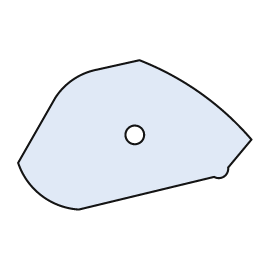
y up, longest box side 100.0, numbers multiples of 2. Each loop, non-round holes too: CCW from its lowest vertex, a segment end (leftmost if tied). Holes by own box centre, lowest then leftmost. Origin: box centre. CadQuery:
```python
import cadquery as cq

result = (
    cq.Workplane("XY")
    .moveTo(-24.0, -32.0)
    .lineTo(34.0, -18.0)
    .threePointArc((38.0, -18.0), (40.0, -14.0))
    .lineTo(50.0, -2.0)
    .threePointArc((28.0, 18.0), (2.0, 32.0))
    .lineTo(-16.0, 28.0)
    .threePointArc((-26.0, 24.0), (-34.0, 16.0))
    .lineTo(-50.0, -12.0)
    .threePointArc((-40.0, -26.0), (-24.0, -32.0))
    .close()
    .moveTo(0.0, 0.0)
    .circle(4.0)
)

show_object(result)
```